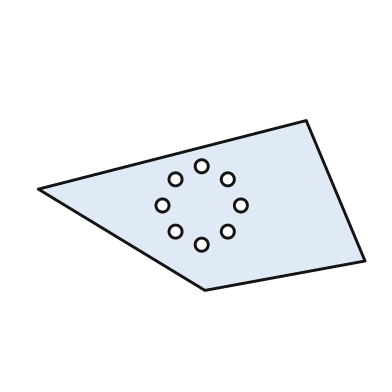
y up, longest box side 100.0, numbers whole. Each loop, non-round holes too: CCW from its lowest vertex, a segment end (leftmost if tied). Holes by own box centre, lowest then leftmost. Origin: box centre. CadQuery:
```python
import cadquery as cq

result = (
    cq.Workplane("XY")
    .moveTo(1.0, -26.0)
    .lineTo(50.0, -17.0)
    .lineTo(32.0, 26.0)
    .lineTo(-50.0, 5.0)
    .close()
    .moveTo(0.0, -12.0)
    .circle(2.0)
    .moveTo(-8.0, -8.0)
    .circle(2.0)
    .moveTo(8.0, -8.0)
    .circle(2.0)
    .moveTo(-12.0, 0.0)
    .circle(2.0)
    .moveTo(12.0, 0.0)
    .circle(2.0)
    .moveTo(-8.0, 8.0)
    .circle(2.0)
    .moveTo(8.0, 8.0)
    .circle(2.0)
    .moveTo(0.0, 12.0)
    .circle(2.0)
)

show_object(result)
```